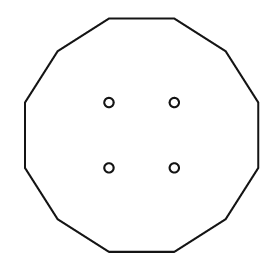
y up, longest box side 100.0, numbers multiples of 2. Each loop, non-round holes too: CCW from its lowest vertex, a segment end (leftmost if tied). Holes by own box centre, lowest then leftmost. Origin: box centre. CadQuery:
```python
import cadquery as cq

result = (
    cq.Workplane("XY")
    .moveTo(-14.0, -50.0)
    .lineTo(14.0, -50.0)
    .lineTo(36.0, -36.0)
    .lineTo(50.0, -14.0)
    .lineTo(50.0, 14.0)
    .lineTo(36.0, 36.0)
    .lineTo(14.0, 50.0)
    .lineTo(-14.0, 50.0)
    .lineTo(-36.0, 36.0)
    .lineTo(-50.0, 14.0)
    .lineTo(-50.0, -14.0)
    .lineTo(-36.0, -36.0)
    .close()
    .moveTo(-14.0, -14.0)
    .circle(2.0)
    .moveTo(14.0, -14.0)
    .circle(2.0)
    .moveTo(-14.0, 14.0)
    .circle(2.0)
    .moveTo(14.0, 14.0)
    .circle(2.0)
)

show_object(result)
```